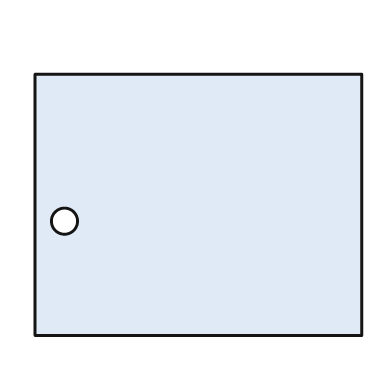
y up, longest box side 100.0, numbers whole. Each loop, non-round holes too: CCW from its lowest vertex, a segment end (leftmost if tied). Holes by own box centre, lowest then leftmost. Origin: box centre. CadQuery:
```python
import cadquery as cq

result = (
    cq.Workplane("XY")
    .moveTo(-50.0, -40.0)
    .lineTo(50.0, -40.0)
    .lineTo(50.0, 40.0)
    .lineTo(-50.0, 40.0)
    .close()
    .moveTo(-41.0, -5.0)
    .circle(4.0)
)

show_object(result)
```